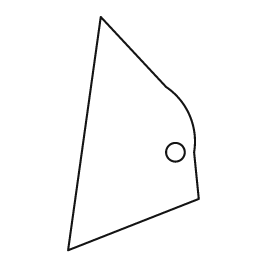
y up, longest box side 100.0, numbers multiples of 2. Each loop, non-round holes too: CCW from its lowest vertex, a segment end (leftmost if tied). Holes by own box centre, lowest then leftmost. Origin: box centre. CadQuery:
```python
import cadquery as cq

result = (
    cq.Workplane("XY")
    .moveTo(-28.0, -50.0)
    .lineTo(28.0, -28.0)
    .lineTo(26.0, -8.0)
    .threePointArc((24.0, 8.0), (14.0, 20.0))
    .lineTo(-14.0, 50.0)
    .close()
    .moveTo(18.0, -8.0)
    .circle(4.0)
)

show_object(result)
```